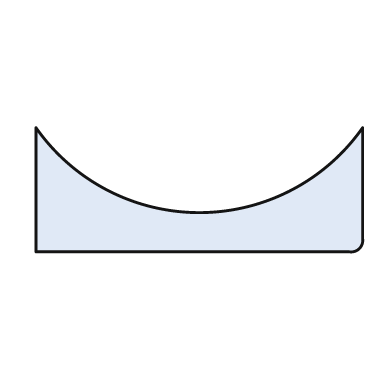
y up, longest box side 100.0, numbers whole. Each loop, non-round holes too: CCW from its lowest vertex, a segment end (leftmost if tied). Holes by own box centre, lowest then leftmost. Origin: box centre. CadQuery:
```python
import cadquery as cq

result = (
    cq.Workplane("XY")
    .moveTo(-50.0, -19.0)
    .lineTo(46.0, -19.0)
    .threePointArc((49.0, -18.0), (50.0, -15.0))
    .lineTo(50.0, 19.0)
    .threePointArc((0.0, -7.0), (-50.0, 19.0))
    .close()
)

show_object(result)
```